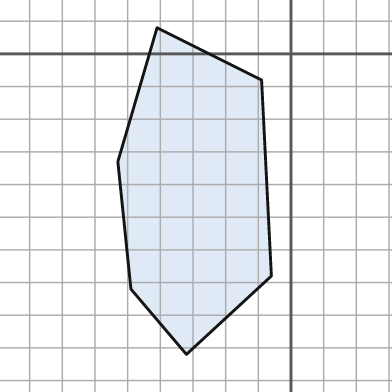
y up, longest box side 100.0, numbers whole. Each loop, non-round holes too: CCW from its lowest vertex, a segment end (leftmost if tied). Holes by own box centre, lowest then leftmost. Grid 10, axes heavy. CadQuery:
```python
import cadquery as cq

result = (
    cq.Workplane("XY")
    .moveTo(-32.0, -92.0)
    .lineTo(-6.0, -68.0)
    .lineTo(-9.0, -8.0)
    .lineTo(-41.0, 8.0)
    .lineTo(-53.0, -33.0)
    .lineTo(-49.0, -72.0)
    .close()
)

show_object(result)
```